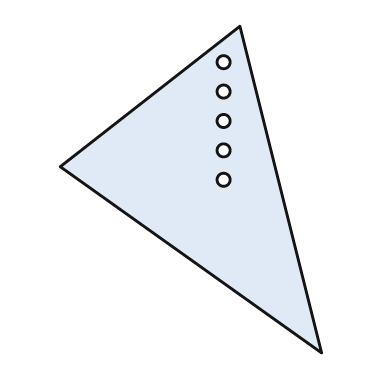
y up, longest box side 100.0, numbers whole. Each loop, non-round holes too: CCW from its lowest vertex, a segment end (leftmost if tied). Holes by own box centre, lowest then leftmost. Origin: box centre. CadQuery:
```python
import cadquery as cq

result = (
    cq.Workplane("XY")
    .moveTo(40.0, -50.0)
    .lineTo(15.0, 50.0)
    .lineTo(-40.0, 7.0)
    .close()
    .moveTo(10.0, 3.0)
    .circle(2.0)
    .moveTo(10.0, 12.0)
    .circle(2.0)
    .moveTo(10.0, 21.0)
    .circle(2.0)
    .moveTo(10.0, 30.0)
    .circle(2.0)
    .moveTo(10.0, 39.0)
    .circle(2.0)
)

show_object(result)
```